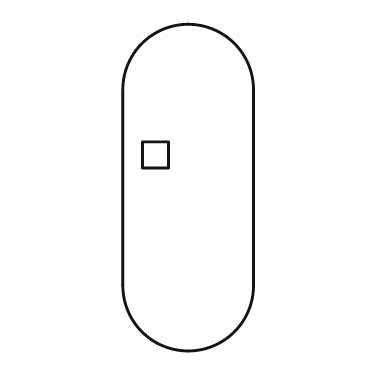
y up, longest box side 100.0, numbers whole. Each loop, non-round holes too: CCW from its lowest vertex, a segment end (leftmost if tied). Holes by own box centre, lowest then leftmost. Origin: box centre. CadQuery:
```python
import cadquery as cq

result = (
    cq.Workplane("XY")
    .moveTo(-20.0, -30.0)
    .threePointArc((0.0, -50.0), (20.0, -30.0))
    .lineTo(20.0, 30.0)
    .threePointArc((0.0, 50.0), (-20.0, 30.0))
    .close()
    .moveTo(-14.0, 6.0)
    .lineTo(-6.0, 6.0)
    .lineTo(-6.0, 14.0)
    .lineTo(-14.0, 14.0)
    .close()
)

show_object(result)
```